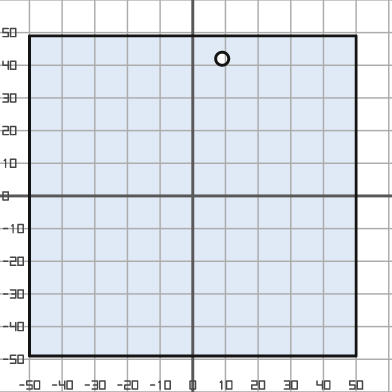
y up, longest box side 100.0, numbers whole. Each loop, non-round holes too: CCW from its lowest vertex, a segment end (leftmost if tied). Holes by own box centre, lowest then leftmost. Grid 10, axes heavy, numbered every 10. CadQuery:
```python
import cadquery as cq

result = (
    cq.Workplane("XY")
    .moveTo(-50.0, -49.0)
    .lineTo(50.0, -49.0)
    .lineTo(50.0, 49.0)
    .lineTo(-50.0, 49.0)
    .close()
    .moveTo(9.0, 42.0)
    .circle(2.0)
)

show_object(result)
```